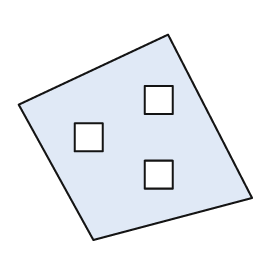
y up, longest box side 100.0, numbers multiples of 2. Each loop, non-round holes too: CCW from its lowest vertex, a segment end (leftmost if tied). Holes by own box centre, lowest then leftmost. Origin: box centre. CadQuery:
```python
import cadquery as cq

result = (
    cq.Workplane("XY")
    .moveTo(-18.0, -44.0)
    .lineTo(50.0, -26.0)
    .lineTo(14.0, 44.0)
    .lineTo(-50.0, 14.0)
    .close()
    .moveTo(4.0, -22.0)
    .lineTo(16.0, -22.0)
    .lineTo(16.0, -10.0)
    .lineTo(4.0, -10.0)
    .close()
    .moveTo(-26.0, -6.0)
    .lineTo(-14.0, -6.0)
    .lineTo(-14.0, 6.0)
    .lineTo(-26.0, 6.0)
    .close()
    .moveTo(4.0, 10.0)
    .lineTo(16.0, 10.0)
    .lineTo(16.0, 22.0)
    .lineTo(4.0, 22.0)
    .close()
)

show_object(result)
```